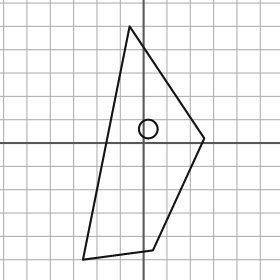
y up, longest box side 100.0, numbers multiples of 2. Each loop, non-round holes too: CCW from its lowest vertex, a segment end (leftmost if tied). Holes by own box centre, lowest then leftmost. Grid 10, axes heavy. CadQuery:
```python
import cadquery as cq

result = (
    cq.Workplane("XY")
    .moveTo(-26.0, -50.0)
    .lineTo(4.0, -46.0)
    .lineTo(26.0, 2.0)
    .lineTo(-6.0, 50.0)
    .close()
    .moveTo(2.0, 6.0)
    .circle(4.0)
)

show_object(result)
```